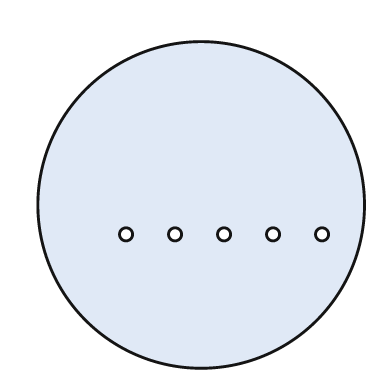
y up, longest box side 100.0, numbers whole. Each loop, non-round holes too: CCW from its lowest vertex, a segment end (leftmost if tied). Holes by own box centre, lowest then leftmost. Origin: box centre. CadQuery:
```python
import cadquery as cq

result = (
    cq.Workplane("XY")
    .moveTo(0.0, 0.0)
    .circle(50.0)
    .moveTo(-23.0, -9.0)
    .circle(2.0)
    .moveTo(-8.0, -9.0)
    .circle(2.0)
    .moveTo(7.0, -9.0)
    .circle(2.0)
    .moveTo(22.0, -9.0)
    .circle(2.0)
    .moveTo(37.0, -9.0)
    .circle(2.0)
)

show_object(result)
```